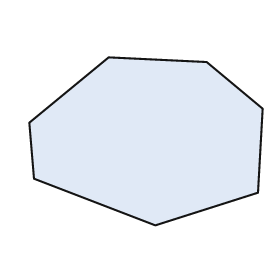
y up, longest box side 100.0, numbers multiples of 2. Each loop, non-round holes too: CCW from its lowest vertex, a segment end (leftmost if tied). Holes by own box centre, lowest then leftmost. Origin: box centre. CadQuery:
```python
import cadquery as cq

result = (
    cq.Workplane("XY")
    .moveTo(4.0, -36.0)
    .lineTo(48.0, -22.0)
    .lineTo(50.0, 14.0)
    .lineTo(26.0, 34.0)
    .lineTo(-16.0, 36.0)
    .lineTo(-50.0, 8.0)
    .lineTo(-48.0, -16.0)
    .close()
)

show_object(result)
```